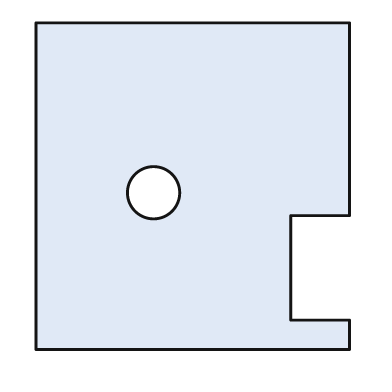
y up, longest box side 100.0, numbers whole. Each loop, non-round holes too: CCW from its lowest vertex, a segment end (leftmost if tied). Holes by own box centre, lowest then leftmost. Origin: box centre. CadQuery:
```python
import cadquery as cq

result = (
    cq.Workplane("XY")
    .moveTo(-48.0, -50.0)
    .lineTo(48.0, -50.0)
    .lineTo(48.0, -41.0)
    .lineTo(30.0, -41.0)
    .lineTo(30.0, -9.0)
    .lineTo(48.0, -9.0)
    .lineTo(48.0, 50.0)
    .lineTo(-48.0, 50.0)
    .close()
    .moveTo(-12.0, -2.0)
    .circle(8.0)
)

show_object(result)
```